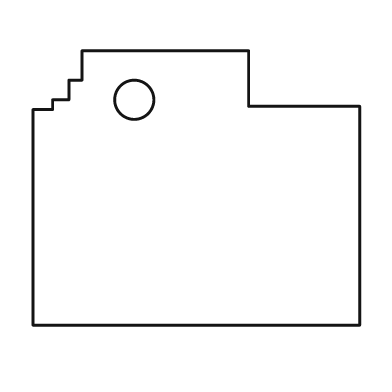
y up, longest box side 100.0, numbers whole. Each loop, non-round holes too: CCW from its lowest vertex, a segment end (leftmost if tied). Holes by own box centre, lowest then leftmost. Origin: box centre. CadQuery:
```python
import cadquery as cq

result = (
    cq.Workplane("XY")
    .moveTo(-50.0, -42.0)
    .lineTo(50.0, -42.0)
    .lineTo(50.0, 25.0)
    .lineTo(16.0, 25.0)
    .lineTo(16.0, 42.0)
    .lineTo(-35.0, 42.0)
    .lineTo(-35.0, 33.0)
    .lineTo(-39.0, 33.0)
    .lineTo(-39.0, 27.0)
    .lineTo(-44.0, 27.0)
    .lineTo(-44.0, 24.0)
    .lineTo(-50.0, 24.0)
    .close()
    .moveTo(-19.0, 27.0)
    .circle(6.0)
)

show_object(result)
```